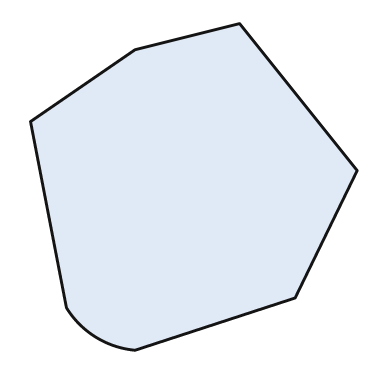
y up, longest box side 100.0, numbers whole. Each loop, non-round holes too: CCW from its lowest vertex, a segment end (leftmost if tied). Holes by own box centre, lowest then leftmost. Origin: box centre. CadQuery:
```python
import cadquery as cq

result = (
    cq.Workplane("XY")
    .moveTo(-18.0, -50.0)
    .lineTo(31.0, -34.0)
    .lineTo(50.0, 5.0)
    .lineTo(14.0, 50.0)
    .lineTo(-18.0, 42.0)
    .lineTo(-50.0, 20.0)
    .lineTo(-39.0, -37.0)
    .threePointArc((-30.0, -46.0), (-18.0, -50.0))
    .close()
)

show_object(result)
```